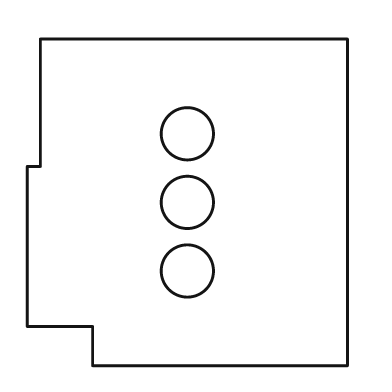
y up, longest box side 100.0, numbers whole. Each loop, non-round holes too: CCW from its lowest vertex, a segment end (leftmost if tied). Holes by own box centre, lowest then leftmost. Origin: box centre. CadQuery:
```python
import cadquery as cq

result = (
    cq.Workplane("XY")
    .moveTo(-29.0, -50.0)
    .lineTo(49.0, -50.0)
    .lineTo(49.0, 50.0)
    .lineTo(-45.0, 50.0)
    .lineTo(-45.0, 11.0)
    .lineTo(-49.0, 11.0)
    .lineTo(-49.0, -38.0)
    .lineTo(-29.0, -38.0)
    .close()
    .moveTo(0.0, -21.0)
    .circle(8.0)
    .moveTo(0.0, 0.0)
    .circle(8.0)
    .moveTo(0.0, 21.0)
    .circle(8.0)
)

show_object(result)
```